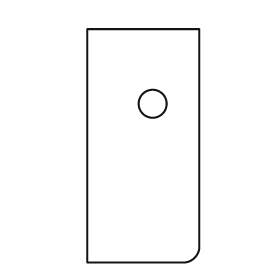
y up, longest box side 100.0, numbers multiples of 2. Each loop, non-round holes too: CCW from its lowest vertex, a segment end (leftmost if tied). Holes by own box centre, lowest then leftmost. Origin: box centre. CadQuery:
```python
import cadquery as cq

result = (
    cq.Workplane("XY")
    .moveTo(-24.0, -50.0)
    .lineTo(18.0, -50.0)
    .threePointArc((22.0, -48.0), (24.0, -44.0))
    .lineTo(24.0, 50.0)
    .lineTo(-24.0, 50.0)
    .close()
    .moveTo(4.0, 18.0)
    .circle(6.0)
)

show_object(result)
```